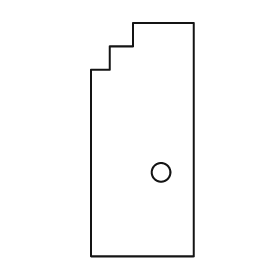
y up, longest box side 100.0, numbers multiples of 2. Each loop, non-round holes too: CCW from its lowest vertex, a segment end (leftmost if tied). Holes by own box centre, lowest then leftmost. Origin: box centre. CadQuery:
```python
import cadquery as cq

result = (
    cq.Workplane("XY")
    .moveTo(-22.0, -50.0)
    .lineTo(22.0, -50.0)
    .lineTo(22.0, 50.0)
    .lineTo(-4.0, 50.0)
    .lineTo(-4.0, 40.0)
    .lineTo(-14.0, 40.0)
    .lineTo(-14.0, 30.0)
    .lineTo(-22.0, 30.0)
    .close()
    .moveTo(8.0, -14.0)
    .circle(4.0)
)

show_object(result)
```